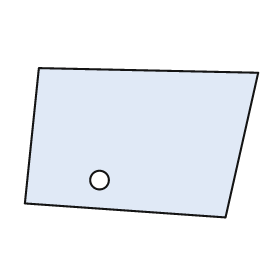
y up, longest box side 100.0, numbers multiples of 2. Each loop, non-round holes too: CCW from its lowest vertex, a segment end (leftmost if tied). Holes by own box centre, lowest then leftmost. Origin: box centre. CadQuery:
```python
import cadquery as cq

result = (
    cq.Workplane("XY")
    .moveTo(36.0, -32.0)
    .lineTo(50.0, 30.0)
    .lineTo(-44.0, 32.0)
    .lineTo(-50.0, -26.0)
    .close()
    .moveTo(-18.0, -16.0)
    .circle(4.0)
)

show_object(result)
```